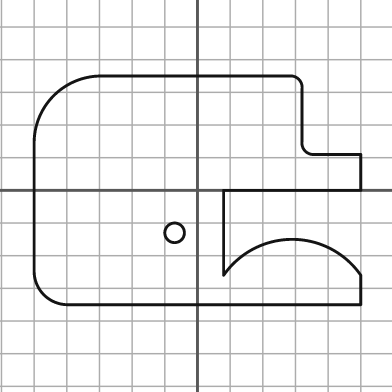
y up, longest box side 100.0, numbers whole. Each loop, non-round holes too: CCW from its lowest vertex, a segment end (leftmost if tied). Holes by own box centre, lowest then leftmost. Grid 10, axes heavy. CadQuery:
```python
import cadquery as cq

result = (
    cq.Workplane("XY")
    .moveTo(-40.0, -35.0)
    .lineTo(50.0, -35.0)
    .lineTo(50.0, -26.0)
    .threePointArc((29.0, -15.0), (8.0, -26.0))
    .lineTo(8.0, 0.0)
    .lineTo(50.0, 0.0)
    .lineTo(50.0, 11.0)
    .lineTo(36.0, 11.0)
    .threePointArc((33.0, 12.0), (32.0, 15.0))
    .lineTo(32.0, 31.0)
    .threePointArc((31.0, 34.0), (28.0, 35.0))
    .lineTo(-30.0, 35.0)
    .threePointArc((-44.0, 29.0), (-50.0, 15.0))
    .lineTo(-50.0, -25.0)
    .threePointArc((-47.0, -32.0), (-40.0, -35.0))
    .close()
    .moveTo(-7.0, -13.0)
    .circle(3.0)
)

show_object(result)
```